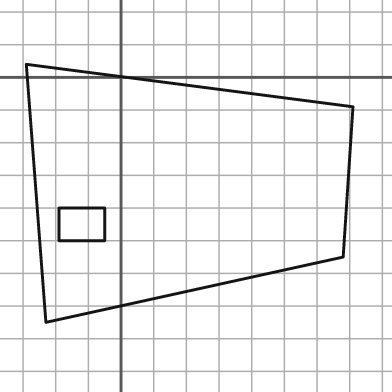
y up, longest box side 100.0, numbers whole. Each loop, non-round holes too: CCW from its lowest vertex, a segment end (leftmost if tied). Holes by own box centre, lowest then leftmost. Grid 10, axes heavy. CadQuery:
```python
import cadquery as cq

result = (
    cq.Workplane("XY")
    .moveTo(-23.0, -75.0)
    .lineTo(68.0, -55.0)
    .lineTo(71.0, -9.0)
    .lineTo(-29.0, 4.0)
    .close()
    .moveTo(-19.0, -50.0)
    .lineTo(-5.0, -50.0)
    .lineTo(-5.0, -40.0)
    .lineTo(-19.0, -40.0)
    .close()
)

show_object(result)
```